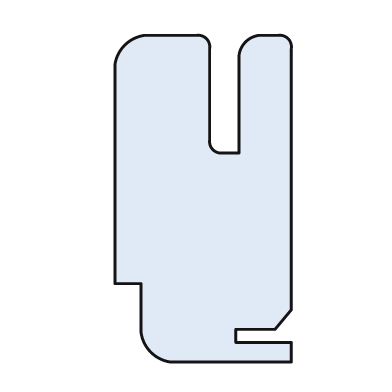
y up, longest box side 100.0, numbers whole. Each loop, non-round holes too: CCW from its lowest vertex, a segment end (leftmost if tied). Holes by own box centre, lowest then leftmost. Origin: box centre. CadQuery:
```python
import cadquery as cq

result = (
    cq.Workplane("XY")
    .moveTo(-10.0, -50.0)
    .lineTo(27.0, -50.0)
    .lineTo(27.0, -44.0)
    .lineTo(10.0, -44.0)
    .lineTo(10.0, -40.0)
    .lineTo(22.0, -40.0)
    .lineTo(27.0, -34.0)
    .lineTo(27.0, 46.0)
    .threePointArc((26.0, 49.0), (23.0, 50.0))
    .lineTo(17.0, 50.0)
    .threePointArc((13.0, 48.0), (11.0, 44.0))
    .lineTo(11.0, 14.0)
    .lineTo(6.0, 14.0)
    .threePointArc((3.0, 15.0), (2.0, 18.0))
    .lineTo(2.0, 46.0)
    .threePointArc((1.0, 49.0), (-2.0, 50.0))
    .lineTo(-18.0, 50.0)
    .threePointArc((-24.0, 47.0), (-27.0, 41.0))
    .lineTo(-27.0, -26.0)
    .lineTo(-19.0, -26.0)
    .lineTo(-19.0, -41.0)
    .threePointArc((-16.0, -47.0), (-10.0, -50.0))
    .close()
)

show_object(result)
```